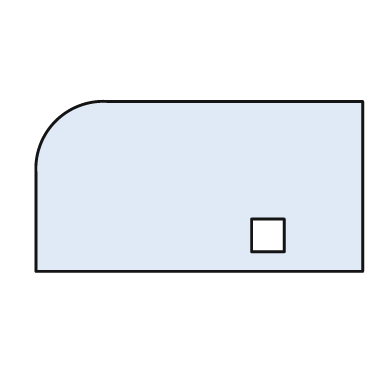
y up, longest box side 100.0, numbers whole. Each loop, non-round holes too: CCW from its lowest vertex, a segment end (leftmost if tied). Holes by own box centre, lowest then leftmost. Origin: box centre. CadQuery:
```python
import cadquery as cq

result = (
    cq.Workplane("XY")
    .moveTo(-50.0, -26.0)
    .lineTo(50.0, -26.0)
    .lineTo(50.0, 26.0)
    .lineTo(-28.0, 26.0)
    .threePointArc((-44.0, 20.0), (-50.0, 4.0))
    .close()
    .moveTo(16.0, -20.0)
    .lineTo(26.0, -20.0)
    .lineTo(26.0, -10.0)
    .lineTo(16.0, -10.0)
    .close()
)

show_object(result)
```